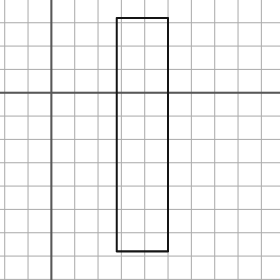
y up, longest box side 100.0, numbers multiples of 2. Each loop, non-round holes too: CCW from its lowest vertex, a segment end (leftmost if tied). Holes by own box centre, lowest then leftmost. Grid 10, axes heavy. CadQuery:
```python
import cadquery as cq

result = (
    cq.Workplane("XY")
    .moveTo(28.0, -68.0)
    .lineTo(50.0, -68.0)
    .lineTo(50.0, 32.0)
    .lineTo(28.0, 32.0)
    .close()
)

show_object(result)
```